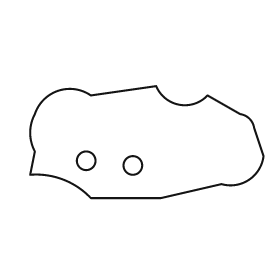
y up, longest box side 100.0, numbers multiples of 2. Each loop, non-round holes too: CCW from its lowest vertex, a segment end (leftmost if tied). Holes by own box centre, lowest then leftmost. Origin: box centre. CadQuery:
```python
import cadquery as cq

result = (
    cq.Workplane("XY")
    .moveTo(-24.0, -24.0)
    .lineTo(6.0, -24.0)
    .lineTo(32.0, -18.0)
    .threePointArc((44.0, -16.0), (50.0, -6.0))
    .lineTo(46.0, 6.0)
    .threePointArc((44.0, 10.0), (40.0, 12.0))
    .lineTo(26.0, 20.0)
    .threePointArc((14.0, 16.0), (4.0, 24.0))
    .lineTo(-24.0, 20.0)
    .threePointArc((-38.0, 22.0), (-48.0, 12.0))
    .threePointArc((-50.0, 4.0), (-48.0, -4.0))
    .lineTo(-50.0, -14.0)
    .threePointArc((-36.0, -16.0), (-24.0, -24.0))
    .close()
    .moveTo(-6.0, -10.0)
    .circle(4.0)
    .moveTo(-26.0, -8.0)
    .circle(4.0)
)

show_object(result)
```